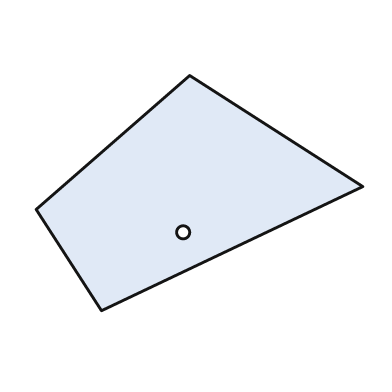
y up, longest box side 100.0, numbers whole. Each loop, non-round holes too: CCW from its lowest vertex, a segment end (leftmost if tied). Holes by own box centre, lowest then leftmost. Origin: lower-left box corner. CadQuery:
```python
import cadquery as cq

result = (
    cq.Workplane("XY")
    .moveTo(20.0, 0.0)
    .lineTo(100.0, 38.0)
    .lineTo(47.0, 72.0)
    .lineTo(0.0, 31.0)
    .close()
    .moveTo(45.0, 24.0)
    .circle(2.0)
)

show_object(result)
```